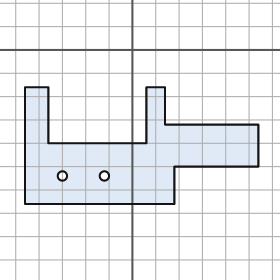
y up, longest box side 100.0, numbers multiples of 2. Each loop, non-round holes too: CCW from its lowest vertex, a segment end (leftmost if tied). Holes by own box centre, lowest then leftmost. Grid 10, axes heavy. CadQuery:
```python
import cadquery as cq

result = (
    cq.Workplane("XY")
    .moveTo(-46.0, -66.0)
    .lineTo(18.0, -66.0)
    .lineTo(18.0, -50.0)
    .lineTo(54.0, -50.0)
    .lineTo(54.0, -32.0)
    .lineTo(14.0, -32.0)
    .lineTo(14.0, -16.0)
    .lineTo(6.0, -16.0)
    .lineTo(6.0, -40.0)
    .lineTo(-36.0, -40.0)
    .lineTo(-36.0, -16.0)
    .lineTo(-46.0, -16.0)
    .close()
    .moveTo(-30.0, -54.0)
    .circle(2.0)
    .moveTo(-12.0, -54.0)
    .circle(2.0)
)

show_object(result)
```